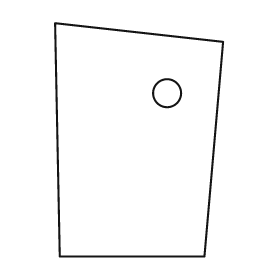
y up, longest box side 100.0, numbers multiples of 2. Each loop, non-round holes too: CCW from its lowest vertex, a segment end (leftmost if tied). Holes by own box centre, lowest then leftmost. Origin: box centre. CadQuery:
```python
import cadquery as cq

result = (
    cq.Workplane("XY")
    .moveTo(-34.0, -50.0)
    .lineTo(28.0, -50.0)
    .lineTo(36.0, 42.0)
    .lineTo(-36.0, 50.0)
    .close()
    .moveTo(12.0, 20.0)
    .circle(6.0)
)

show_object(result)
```